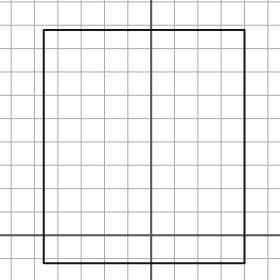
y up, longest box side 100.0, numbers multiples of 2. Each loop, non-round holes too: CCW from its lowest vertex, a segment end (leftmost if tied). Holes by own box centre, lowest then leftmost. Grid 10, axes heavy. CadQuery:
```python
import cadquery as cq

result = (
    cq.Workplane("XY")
    .moveTo(-46.0, -12.0)
    .lineTo(40.0, -12.0)
    .lineTo(40.0, 88.0)
    .lineTo(-46.0, 88.0)
    .close()
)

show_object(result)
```